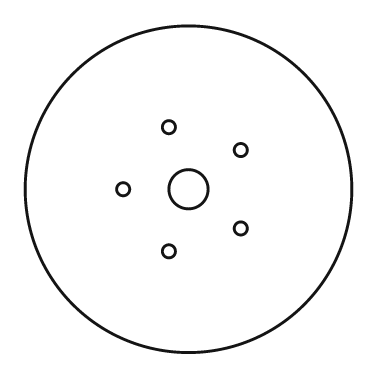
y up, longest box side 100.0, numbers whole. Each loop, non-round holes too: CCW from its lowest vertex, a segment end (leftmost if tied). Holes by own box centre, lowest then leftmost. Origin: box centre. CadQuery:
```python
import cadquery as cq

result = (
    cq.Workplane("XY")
    .moveTo(0.0, 0.0)
    .circle(50.0)
    .moveTo(-6.0, -19.0)
    .circle(2.0)
    .moveTo(16.0, -12.0)
    .circle(2.0)
    .moveTo(-20.0, 0.0)
    .circle(2.0)
    .moveTo(0.0, 0.0)
    .circle(6.0)
    .moveTo(16.0, 12.0)
    .circle(2.0)
    .moveTo(-6.0, 19.0)
    .circle(2.0)
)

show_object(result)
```